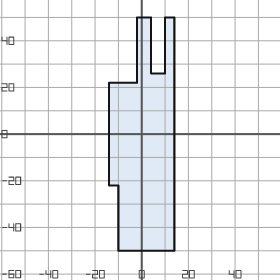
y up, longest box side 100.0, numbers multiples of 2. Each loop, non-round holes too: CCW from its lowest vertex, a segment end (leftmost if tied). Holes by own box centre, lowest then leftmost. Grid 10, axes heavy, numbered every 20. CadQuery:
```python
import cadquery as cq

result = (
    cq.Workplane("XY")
    .moveTo(-10.0, -50.0)
    .lineTo(14.0, -50.0)
    .lineTo(14.0, 50.0)
    .lineTo(10.0, 50.0)
    .lineTo(10.0, 26.0)
    .lineTo(4.0, 26.0)
    .lineTo(4.0, 50.0)
    .lineTo(-2.0, 50.0)
    .lineTo(-2.0, 22.0)
    .lineTo(-14.0, 22.0)
    .lineTo(-14.0, -22.0)
    .lineTo(-10.0, -22.0)
    .close()
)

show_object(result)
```